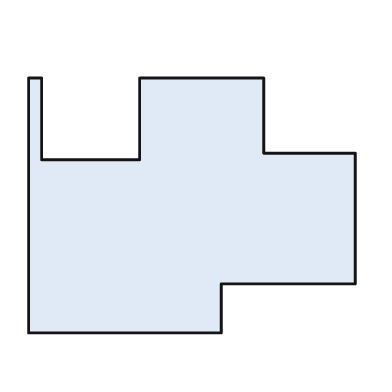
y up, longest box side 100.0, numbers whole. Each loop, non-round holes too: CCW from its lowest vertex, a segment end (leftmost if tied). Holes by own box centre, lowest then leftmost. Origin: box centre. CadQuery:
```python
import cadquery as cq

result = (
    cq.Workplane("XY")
    .moveTo(-50.0, -39.0)
    .lineTo(9.0, -39.0)
    .lineTo(9.0, -24.0)
    .lineTo(50.0, -24.0)
    .lineTo(50.0, 16.0)
    .lineTo(22.0, 16.0)
    .lineTo(22.0, 39.0)
    .lineTo(-16.0, 39.0)
    .lineTo(-16.0, 14.0)
    .lineTo(-46.0, 14.0)
    .lineTo(-46.0, 39.0)
    .lineTo(-50.0, 39.0)
    .close()
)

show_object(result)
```